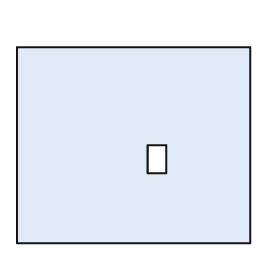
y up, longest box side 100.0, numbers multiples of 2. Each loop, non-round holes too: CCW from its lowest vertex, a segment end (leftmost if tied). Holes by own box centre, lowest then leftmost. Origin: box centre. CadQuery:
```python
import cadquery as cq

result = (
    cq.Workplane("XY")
    .moveTo(-50.0, -42.0)
    .lineTo(50.0, -42.0)
    .lineTo(50.0, 42.0)
    .lineTo(-50.0, 42.0)
    .close()
    .moveTo(6.0, -12.0)
    .lineTo(14.0, -12.0)
    .lineTo(14.0, 0.0)
    .lineTo(6.0, 0.0)
    .close()
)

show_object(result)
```